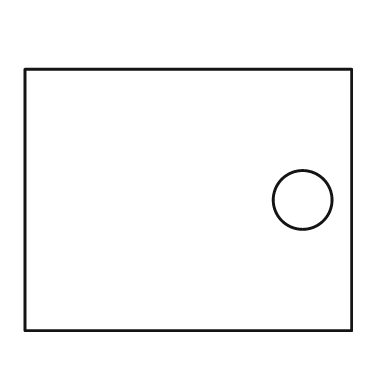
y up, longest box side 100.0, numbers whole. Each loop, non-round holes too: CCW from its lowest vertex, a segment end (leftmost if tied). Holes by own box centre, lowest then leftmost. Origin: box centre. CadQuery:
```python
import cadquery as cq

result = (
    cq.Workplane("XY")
    .moveTo(-50.0, -40.0)
    .lineTo(50.0, -40.0)
    .lineTo(50.0, 40.0)
    .lineTo(-50.0, 40.0)
    .close()
    .moveTo(35.0, 0.0)
    .circle(9.0)
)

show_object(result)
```